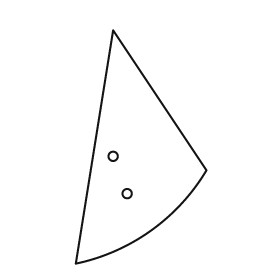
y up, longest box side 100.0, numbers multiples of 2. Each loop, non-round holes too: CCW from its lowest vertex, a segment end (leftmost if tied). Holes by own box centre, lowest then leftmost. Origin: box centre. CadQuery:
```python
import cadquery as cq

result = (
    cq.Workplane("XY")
    .moveTo(-28.0, -50.0)
    .threePointArc((4.0, -36.0), (28.0, -10.0))
    .lineTo(-12.0, 50.0)
    .close()
    .moveTo(-6.0, -20.0)
    .circle(2.0)
    .moveTo(-12.0, -4.0)
    .circle(2.0)
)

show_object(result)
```